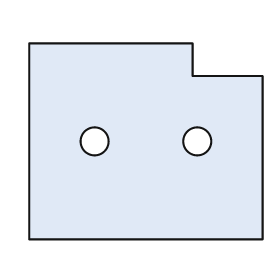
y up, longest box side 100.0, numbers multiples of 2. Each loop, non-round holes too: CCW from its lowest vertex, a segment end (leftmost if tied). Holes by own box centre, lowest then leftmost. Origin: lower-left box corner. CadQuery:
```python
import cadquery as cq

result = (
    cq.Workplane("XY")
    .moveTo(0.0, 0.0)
    .lineTo(100.0, 0.0)
    .lineTo(100.0, 70.0)
    .lineTo(70.0, 70.0)
    .lineTo(70.0, 84.0)
    .lineTo(0.0, 84.0)
    .close()
    .moveTo(28.0, 42.0)
    .circle(6.0)
    .moveTo(72.0, 42.0)
    .circle(6.0)
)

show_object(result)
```